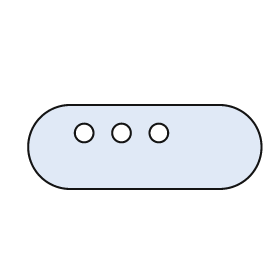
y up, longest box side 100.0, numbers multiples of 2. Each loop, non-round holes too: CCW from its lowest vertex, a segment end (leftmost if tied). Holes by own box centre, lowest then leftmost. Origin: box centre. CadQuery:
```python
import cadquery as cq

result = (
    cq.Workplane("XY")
    .moveTo(-32.0, -18.0)
    .lineTo(32.0, -18.0)
    .threePointArc((50.0, 0.0), (32.0, 18.0))
    .lineTo(-32.0, 18.0)
    .threePointArc((-50.0, 0.0), (-32.0, -18.0))
    .close()
    .moveTo(-26.0, 6.0)
    .circle(4.0)
    .moveTo(-10.0, 6.0)
    .circle(4.0)
    .moveTo(6.0, 6.0)
    .circle(4.0)
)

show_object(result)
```